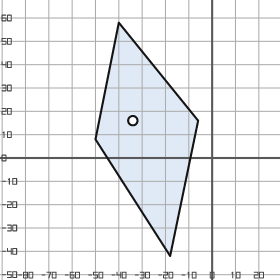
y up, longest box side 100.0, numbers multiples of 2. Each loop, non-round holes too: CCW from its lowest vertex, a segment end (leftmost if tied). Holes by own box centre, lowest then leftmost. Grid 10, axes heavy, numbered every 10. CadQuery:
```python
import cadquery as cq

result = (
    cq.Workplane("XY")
    .moveTo(-18.0, -42.0)
    .lineTo(-6.0, 16.0)
    .lineTo(-40.0, 58.0)
    .lineTo(-50.0, 8.0)
    .close()
    .moveTo(-34.0, 16.0)
    .circle(2.0)
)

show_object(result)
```